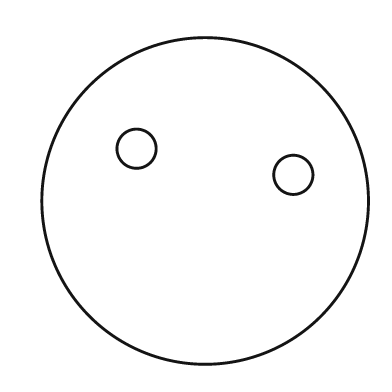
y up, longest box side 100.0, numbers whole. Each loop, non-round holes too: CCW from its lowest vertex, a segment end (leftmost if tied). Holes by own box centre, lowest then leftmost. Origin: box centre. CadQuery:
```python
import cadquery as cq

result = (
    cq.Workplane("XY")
    .moveTo(0.0, 0.0)
    .circle(50.0)
    .moveTo(27.0, 8.0)
    .circle(6.0)
    .moveTo(-21.0, 16.0)
    .circle(6.0)
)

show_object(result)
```